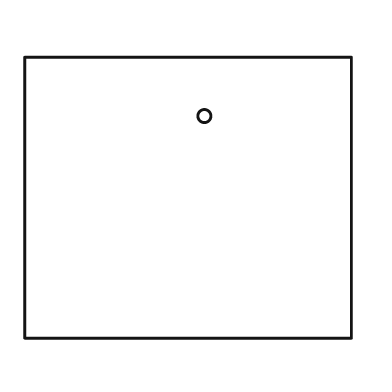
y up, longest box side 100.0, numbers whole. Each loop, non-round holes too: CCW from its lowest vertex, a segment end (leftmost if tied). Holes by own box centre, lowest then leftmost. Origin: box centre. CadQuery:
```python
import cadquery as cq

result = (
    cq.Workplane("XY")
    .moveTo(-50.0, -43.0)
    .lineTo(50.0, -43.0)
    .lineTo(50.0, 43.0)
    .lineTo(-50.0, 43.0)
    .close()
    .moveTo(5.0, 25.0)
    .circle(2.0)
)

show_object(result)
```